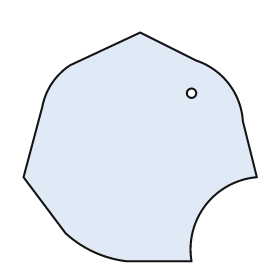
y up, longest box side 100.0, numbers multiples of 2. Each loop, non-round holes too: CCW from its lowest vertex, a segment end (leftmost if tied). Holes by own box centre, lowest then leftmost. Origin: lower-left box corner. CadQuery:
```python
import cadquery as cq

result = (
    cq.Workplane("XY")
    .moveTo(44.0, 0.0)
    .lineTo(72.0, 0.0)
    .threePointArc((78.0, 24.0), (100.0, 36.0))
    .lineTo(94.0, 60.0)
    .threePointArc((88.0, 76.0), (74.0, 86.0))
    .lineTo(50.0, 98.0)
    .lineTo(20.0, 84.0)
    .threePointArc((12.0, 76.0), (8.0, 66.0))
    .lineTo(0.0, 36.0)
    .lineTo(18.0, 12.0)
    .threePointArc((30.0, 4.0), (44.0, 0.0))
    .close()
    .moveTo(72.0, 72.0)
    .circle(2.0)
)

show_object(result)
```